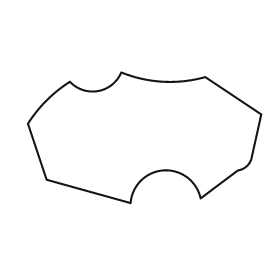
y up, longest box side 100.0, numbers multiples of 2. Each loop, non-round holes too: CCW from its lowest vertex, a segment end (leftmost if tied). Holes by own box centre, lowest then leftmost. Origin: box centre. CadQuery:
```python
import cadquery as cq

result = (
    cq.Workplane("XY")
    .moveTo(-6.0, -28.0)
    .threePointArc((8.0, -14.0), (24.0, -26.0))
    .lineTo(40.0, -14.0)
    .threePointArc((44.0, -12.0), (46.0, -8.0))
    .lineTo(50.0, 10.0)
    .lineTo(26.0, 26.0)
    .threePointArc((8.0, 24.0), (-10.0, 28.0))
    .threePointArc((-20.0, 20.0), (-32.0, 24.0))
    .threePointArc((-42.0, 16.0), (-50.0, 6.0))
    .lineTo(-42.0, -18.0)
    .close()
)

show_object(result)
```